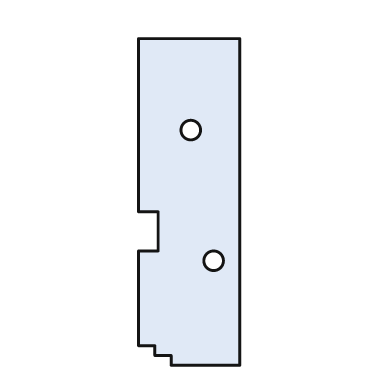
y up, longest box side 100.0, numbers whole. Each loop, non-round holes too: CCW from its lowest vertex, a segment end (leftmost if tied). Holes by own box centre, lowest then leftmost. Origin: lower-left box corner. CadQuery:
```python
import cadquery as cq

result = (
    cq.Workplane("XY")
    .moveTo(10.0, 0.0)
    .lineTo(31.0, 0.0)
    .lineTo(31.0, 100.0)
    .lineTo(0.0, 100.0)
    .lineTo(0.0, 47.0)
    .lineTo(6.0, 47.0)
    .lineTo(6.0, 35.0)
    .lineTo(0.0, 35.0)
    .lineTo(0.0, 6.0)
    .lineTo(5.0, 6.0)
    .lineTo(5.0, 3.0)
    .lineTo(10.0, 3.0)
    .close()
    .moveTo(23.0, 32.0)
    .circle(3.0)
    .moveTo(16.0, 72.0)
    .circle(3.0)
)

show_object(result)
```